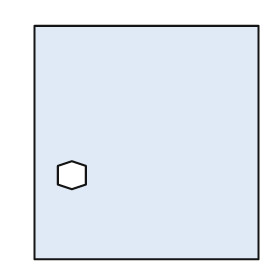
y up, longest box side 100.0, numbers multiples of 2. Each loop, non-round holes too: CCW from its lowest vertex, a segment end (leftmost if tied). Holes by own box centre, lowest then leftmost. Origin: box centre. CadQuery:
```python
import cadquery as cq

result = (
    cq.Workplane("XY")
    .moveTo(-48.0, -50.0)
    .lineTo(48.0, -50.0)
    .lineTo(48.0, 50.0)
    .lineTo(-48.0, 50.0)
    .close()
    .moveTo(-32.0, -20.0)
    .lineTo(-26.0, -18.0)
    .lineTo(-26.0, -10.0)
    .lineTo(-32.0, -8.0)
    .lineTo(-38.0, -10.0)
    .lineTo(-38.0, -18.0)
    .close()
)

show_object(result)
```